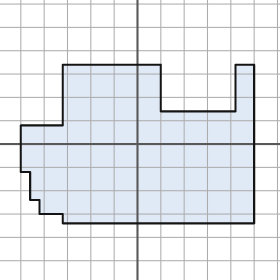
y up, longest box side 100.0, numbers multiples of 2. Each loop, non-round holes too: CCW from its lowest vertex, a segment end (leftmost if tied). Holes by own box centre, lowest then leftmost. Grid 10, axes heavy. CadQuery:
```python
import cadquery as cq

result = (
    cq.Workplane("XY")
    .moveTo(-32.0, -34.0)
    .lineTo(50.0, -34.0)
    .lineTo(50.0, 34.0)
    .lineTo(42.0, 34.0)
    .lineTo(42.0, 14.0)
    .lineTo(10.0, 14.0)
    .lineTo(10.0, 34.0)
    .lineTo(-32.0, 34.0)
    .lineTo(-32.0, 8.0)
    .lineTo(-50.0, 8.0)
    .lineTo(-50.0, -12.0)
    .lineTo(-46.0, -12.0)
    .lineTo(-46.0, -24.0)
    .lineTo(-42.0, -24.0)
    .lineTo(-42.0, -30.0)
    .lineTo(-32.0, -30.0)
    .close()
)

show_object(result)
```